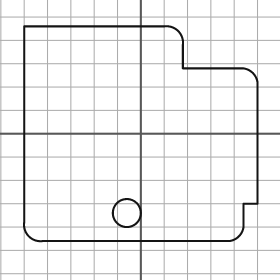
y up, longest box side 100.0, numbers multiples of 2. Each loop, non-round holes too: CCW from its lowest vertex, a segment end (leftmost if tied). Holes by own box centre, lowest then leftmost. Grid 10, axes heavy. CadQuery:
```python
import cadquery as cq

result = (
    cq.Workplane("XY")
    .moveTo(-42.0, -46.0)
    .lineTo(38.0, -46.0)
    .threePointArc((42.0, -44.0), (44.0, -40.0))
    .lineTo(44.0, -30.0)
    .lineTo(50.0, -30.0)
    .lineTo(50.0, 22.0)
    .threePointArc((48.0, 26.0), (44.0, 28.0))
    .lineTo(18.0, 28.0)
    .lineTo(18.0, 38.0)
    .threePointArc((16.0, 44.0), (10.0, 46.0))
    .lineTo(-50.0, 46.0)
    .lineTo(-50.0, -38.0)
    .threePointArc((-48.0, -44.0), (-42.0, -46.0))
    .close()
    .moveTo(-6.0, -34.0)
    .circle(6.0)
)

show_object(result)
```